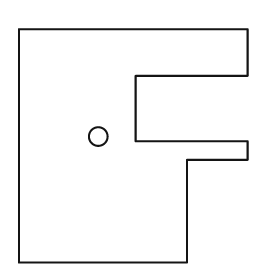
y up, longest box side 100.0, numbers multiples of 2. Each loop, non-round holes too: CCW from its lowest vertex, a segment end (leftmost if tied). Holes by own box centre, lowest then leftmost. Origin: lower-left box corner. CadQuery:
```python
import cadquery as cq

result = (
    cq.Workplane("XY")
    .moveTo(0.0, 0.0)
    .lineTo(72.0, 0.0)
    .lineTo(72.0, 44.0)
    .lineTo(98.0, 44.0)
    .lineTo(98.0, 52.0)
    .lineTo(50.0, 52.0)
    .lineTo(50.0, 80.0)
    .lineTo(98.0, 80.0)
    .lineTo(98.0, 100.0)
    .lineTo(0.0, 100.0)
    .close()
    .moveTo(34.0, 54.0)
    .circle(4.0)
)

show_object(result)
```